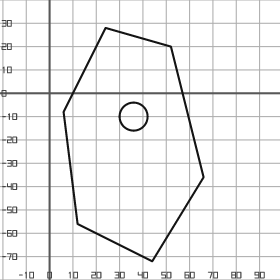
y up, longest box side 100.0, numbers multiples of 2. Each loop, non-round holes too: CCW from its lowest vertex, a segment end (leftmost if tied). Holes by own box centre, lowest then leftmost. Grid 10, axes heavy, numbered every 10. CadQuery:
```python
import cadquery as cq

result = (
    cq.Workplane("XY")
    .moveTo(44.0, -72.0)
    .lineTo(66.0, -36.0)
    .lineTo(52.0, 20.0)
    .lineTo(24.0, 28.0)
    .lineTo(6.0, -8.0)
    .lineTo(12.0, -56.0)
    .close()
    .moveTo(36.0, -10.0)
    .circle(6.0)
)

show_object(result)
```